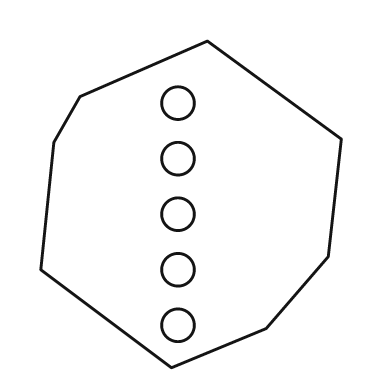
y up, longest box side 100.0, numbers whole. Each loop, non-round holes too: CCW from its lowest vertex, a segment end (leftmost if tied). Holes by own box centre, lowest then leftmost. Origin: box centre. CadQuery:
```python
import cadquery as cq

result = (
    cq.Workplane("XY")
    .moveTo(-6.0, -50.0)
    .lineTo(23.0, -38.0)
    .lineTo(42.0, -16.0)
    .lineTo(46.0, 20.0)
    .lineTo(5.0, 50.0)
    .lineTo(-34.0, 33.0)
    .lineTo(-42.0, 19.0)
    .lineTo(-46.0, -20.0)
    .close()
    .moveTo(-4.0, -37.0)
    .circle(5.0)
    .moveTo(-4.0, -20.0)
    .circle(5.0)
    .moveTo(-4.0, -3.0)
    .circle(5.0)
    .moveTo(-4.0, 14.0)
    .circle(5.0)
    .moveTo(-4.0, 31.0)
    .circle(5.0)
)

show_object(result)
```